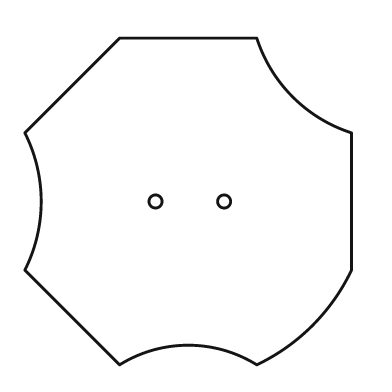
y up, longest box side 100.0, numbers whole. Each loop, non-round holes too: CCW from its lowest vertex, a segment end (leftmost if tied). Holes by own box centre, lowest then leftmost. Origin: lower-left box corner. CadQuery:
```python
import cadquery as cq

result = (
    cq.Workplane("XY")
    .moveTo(29.0, 0.0)
    .threePointArc((50.0, 6.0), (71.0, 0.0))
    .threePointArc((88.0, 12.0), (100.0, 29.0))
    .lineTo(100.0, 71.0)
    .threePointArc((82.0, 82.0), (71.0, 100.0))
    .lineTo(29.0, 100.0)
    .lineTo(0.0, 71.0)
    .threePointArc((5.0, 50.0), (0.0, 29.0))
    .close()
    .moveTo(40.0, 50.0)
    .circle(2.0)
    .moveTo(61.0, 50.0)
    .circle(2.0)
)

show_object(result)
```